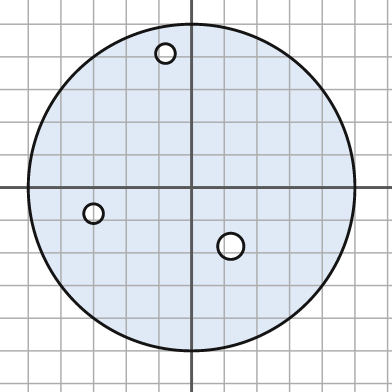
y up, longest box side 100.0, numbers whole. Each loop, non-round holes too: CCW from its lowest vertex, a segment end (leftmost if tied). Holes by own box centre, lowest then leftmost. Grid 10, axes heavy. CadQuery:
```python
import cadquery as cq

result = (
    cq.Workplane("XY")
    .moveTo(0.0, 0.0)
    .circle(50.0)
    .moveTo(12.0, -18.0)
    .circle(4.0)
    .moveTo(-30.0, -8.0)
    .circle(3.0)
    .moveTo(-8.0, 41.0)
    .circle(3.0)
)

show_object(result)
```